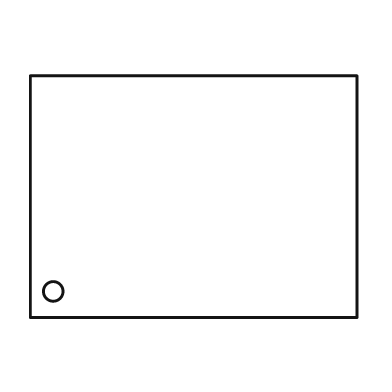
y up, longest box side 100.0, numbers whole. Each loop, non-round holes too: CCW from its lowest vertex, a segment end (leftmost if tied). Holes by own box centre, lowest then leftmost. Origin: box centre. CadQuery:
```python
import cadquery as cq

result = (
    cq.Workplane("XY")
    .moveTo(-50.0, -37.0)
    .lineTo(50.0, -37.0)
    .lineTo(50.0, 37.0)
    .lineTo(-50.0, 37.0)
    .close()
    .moveTo(-43.0, -29.0)
    .circle(3.0)
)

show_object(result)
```